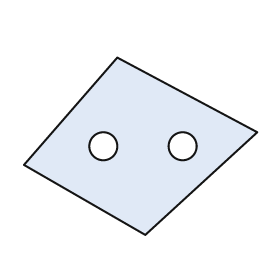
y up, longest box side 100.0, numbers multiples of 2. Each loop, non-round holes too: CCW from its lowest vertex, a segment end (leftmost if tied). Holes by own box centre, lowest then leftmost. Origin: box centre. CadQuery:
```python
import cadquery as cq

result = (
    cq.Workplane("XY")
    .moveTo(2.0, -38.0)
    .lineTo(50.0, 6.0)
    .lineTo(-10.0, 38.0)
    .lineTo(-50.0, -8.0)
    .close()
    .moveTo(-16.0, 0.0)
    .circle(6.0)
    .moveTo(18.0, 0.0)
    .circle(6.0)
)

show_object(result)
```